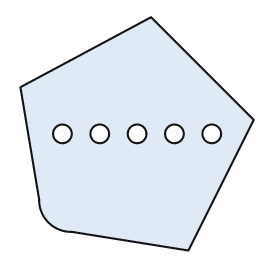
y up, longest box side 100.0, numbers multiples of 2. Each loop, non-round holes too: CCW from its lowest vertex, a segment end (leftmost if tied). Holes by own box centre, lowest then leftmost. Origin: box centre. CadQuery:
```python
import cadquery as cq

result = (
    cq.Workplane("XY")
    .moveTo(22.0, -50.0)
    .lineTo(50.0, 6.0)
    .lineTo(6.0, 50.0)
    .lineTo(-50.0, 20.0)
    .lineTo(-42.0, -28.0)
    .threePointArc((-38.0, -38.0), (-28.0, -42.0))
    .close()
    .moveTo(-32.0, 0.0)
    .circle(4.0)
    .moveTo(-16.0, 0.0)
    .circle(4.0)
    .moveTo(0.0, 0.0)
    .circle(4.0)
    .moveTo(16.0, 0.0)
    .circle(4.0)
    .moveTo(32.0, 0.0)
    .circle(4.0)
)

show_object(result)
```